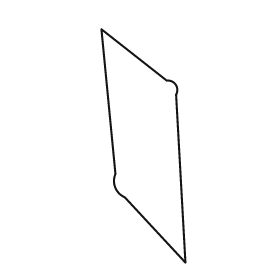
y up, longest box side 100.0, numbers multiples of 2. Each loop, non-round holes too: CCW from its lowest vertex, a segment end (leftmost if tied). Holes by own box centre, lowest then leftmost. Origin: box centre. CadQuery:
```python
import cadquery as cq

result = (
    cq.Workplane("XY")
    .moveTo(18.0, -50.0)
    .lineTo(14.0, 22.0)
    .threePointArc((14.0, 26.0), (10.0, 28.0))
    .lineTo(-18.0, 50.0)
    .lineTo(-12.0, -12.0)
    .threePointArc((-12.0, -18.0), (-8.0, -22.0))
    .close()
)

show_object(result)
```